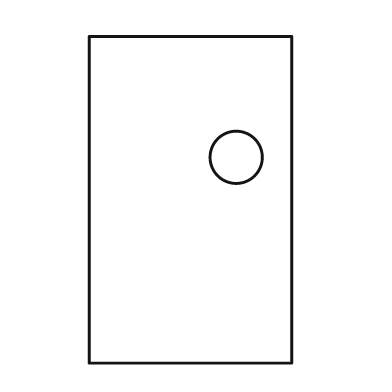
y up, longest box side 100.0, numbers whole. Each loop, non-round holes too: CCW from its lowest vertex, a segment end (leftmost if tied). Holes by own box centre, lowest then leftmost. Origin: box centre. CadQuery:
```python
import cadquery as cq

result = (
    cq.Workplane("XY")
    .moveTo(-31.0, -50.0)
    .lineTo(31.0, -50.0)
    .lineTo(31.0, 50.0)
    .lineTo(-31.0, 50.0)
    .close()
    .moveTo(14.0, 13.0)
    .circle(8.0)
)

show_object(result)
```